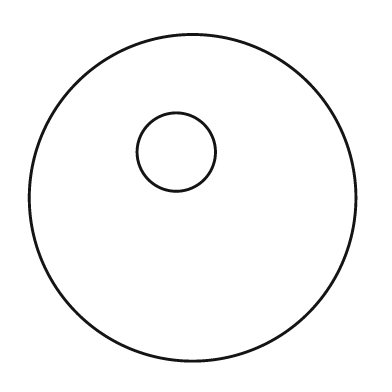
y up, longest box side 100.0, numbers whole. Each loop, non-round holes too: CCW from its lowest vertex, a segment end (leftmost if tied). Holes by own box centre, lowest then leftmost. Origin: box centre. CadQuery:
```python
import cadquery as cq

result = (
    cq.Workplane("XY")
    .moveTo(0.0, 0.0)
    .circle(50.0)
    .moveTo(-5.0, 14.0)
    .circle(12.0)
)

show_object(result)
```